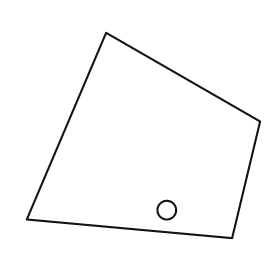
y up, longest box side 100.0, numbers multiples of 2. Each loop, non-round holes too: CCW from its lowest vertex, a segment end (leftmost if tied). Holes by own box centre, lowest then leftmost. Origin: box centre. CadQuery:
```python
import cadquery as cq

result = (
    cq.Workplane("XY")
    .moveTo(38.0, -44.0)
    .lineTo(50.0, 6.0)
    .lineTo(-16.0, 44.0)
    .lineTo(-50.0, -36.0)
    .close()
    .moveTo(10.0, -32.0)
    .circle(4.0)
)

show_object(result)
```